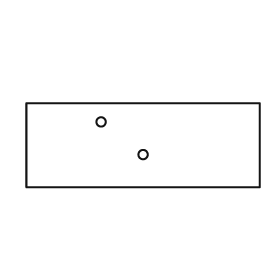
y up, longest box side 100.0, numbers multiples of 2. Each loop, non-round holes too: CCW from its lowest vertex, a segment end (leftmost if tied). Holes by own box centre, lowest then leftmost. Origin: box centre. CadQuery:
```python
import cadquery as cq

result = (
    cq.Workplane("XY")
    .moveTo(-50.0, -18.0)
    .lineTo(50.0, -18.0)
    .lineTo(50.0, 18.0)
    .lineTo(-50.0, 18.0)
    .close()
    .moveTo(0.0, -4.0)
    .circle(2.0)
    .moveTo(-18.0, 10.0)
    .circle(2.0)
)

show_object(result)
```